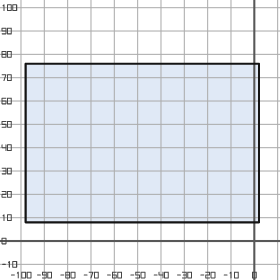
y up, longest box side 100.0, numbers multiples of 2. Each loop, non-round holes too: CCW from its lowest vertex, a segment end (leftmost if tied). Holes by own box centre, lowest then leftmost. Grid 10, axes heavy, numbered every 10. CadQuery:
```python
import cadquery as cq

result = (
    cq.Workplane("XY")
    .moveTo(-98.0, 8.0)
    .lineTo(2.0, 8.0)
    .lineTo(2.0, 76.0)
    .lineTo(-98.0, 76.0)
    .close()
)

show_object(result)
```